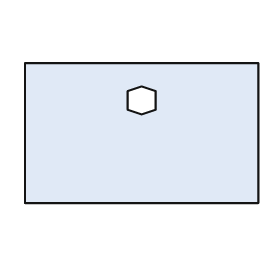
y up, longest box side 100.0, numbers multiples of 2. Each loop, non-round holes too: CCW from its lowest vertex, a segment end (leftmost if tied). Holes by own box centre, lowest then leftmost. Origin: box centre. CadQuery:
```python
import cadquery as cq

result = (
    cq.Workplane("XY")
    .moveTo(-50.0, -30.0)
    .lineTo(50.0, -30.0)
    .lineTo(50.0, 30.0)
    .lineTo(-50.0, 30.0)
    .close()
    .moveTo(0.0, 8.0)
    .lineTo(6.0, 10.0)
    .lineTo(6.0, 18.0)
    .lineTo(0.0, 20.0)
    .lineTo(-6.0, 18.0)
    .lineTo(-6.0, 10.0)
    .close()
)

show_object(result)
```